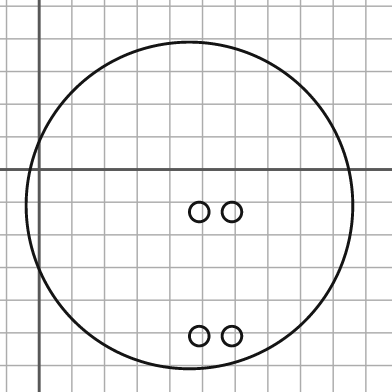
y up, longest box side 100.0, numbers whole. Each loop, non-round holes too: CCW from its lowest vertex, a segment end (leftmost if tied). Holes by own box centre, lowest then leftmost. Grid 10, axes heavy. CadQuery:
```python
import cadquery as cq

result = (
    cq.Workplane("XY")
    .moveTo(46.0, -11.0)
    .circle(50.0)
    .moveTo(49.0, -51.0)
    .circle(3.0)
    .moveTo(59.0, -51.0)
    .circle(3.0)
    .moveTo(49.0, -13.0)
    .circle(3.0)
    .moveTo(59.0, -13.0)
    .circle(3.0)
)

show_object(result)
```